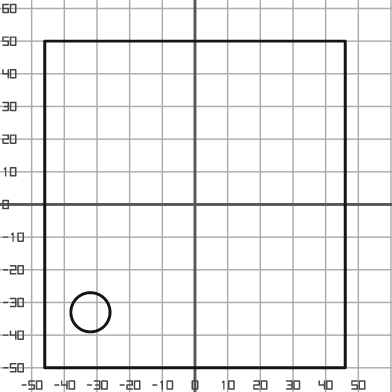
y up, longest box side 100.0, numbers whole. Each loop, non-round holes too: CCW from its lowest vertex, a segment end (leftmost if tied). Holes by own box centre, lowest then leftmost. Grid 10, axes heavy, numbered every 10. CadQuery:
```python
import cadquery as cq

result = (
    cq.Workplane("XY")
    .moveTo(-46.0, -50.0)
    .lineTo(46.0, -50.0)
    .lineTo(46.0, 50.0)
    .lineTo(-46.0, 50.0)
    .close()
    .moveTo(-32.0, -33.0)
    .circle(6.0)
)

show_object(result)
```